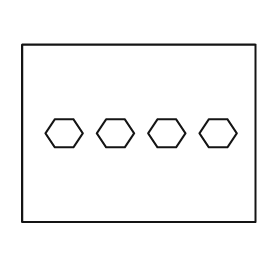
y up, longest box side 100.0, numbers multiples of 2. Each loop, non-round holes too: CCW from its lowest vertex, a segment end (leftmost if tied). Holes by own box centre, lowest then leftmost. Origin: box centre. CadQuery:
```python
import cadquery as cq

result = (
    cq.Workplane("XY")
    .moveTo(-50.0, -38.0)
    .lineTo(50.0, -38.0)
    .lineTo(50.0, 38.0)
    .lineTo(-50.0, 38.0)
    .close()
    .moveTo(-36.0, -6.0)
    .lineTo(-28.0, -6.0)
    .lineTo(-24.0, 0.0)
    .lineTo(-28.0, 6.0)
    .lineTo(-36.0, 6.0)
    .lineTo(-40.0, 0.0)
    .close()
    .moveTo(-14.0, -6.0)
    .lineTo(-6.0, -6.0)
    .lineTo(-2.0, 0.0)
    .lineTo(-6.0, 6.0)
    .lineTo(-14.0, 6.0)
    .lineTo(-18.0, 0.0)
    .close()
    .moveTo(8.0, -6.0)
    .lineTo(16.0, -6.0)
    .lineTo(20.0, 0.0)
    .lineTo(16.0, 6.0)
    .lineTo(8.0, 6.0)
    .lineTo(4.0, 0.0)
    .close()
    .moveTo(30.0, -6.0)
    .lineTo(38.0, -6.0)
    .lineTo(42.0, 0.0)
    .lineTo(38.0, 6.0)
    .lineTo(30.0, 6.0)
    .lineTo(26.0, 0.0)
    .close()
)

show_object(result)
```